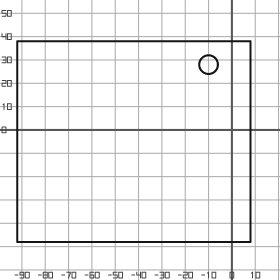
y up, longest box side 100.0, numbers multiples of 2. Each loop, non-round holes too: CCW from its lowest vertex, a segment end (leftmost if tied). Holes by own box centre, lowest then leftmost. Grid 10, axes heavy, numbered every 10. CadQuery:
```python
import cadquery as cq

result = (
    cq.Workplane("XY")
    .moveTo(-92.0, -48.0)
    .lineTo(8.0, -48.0)
    .lineTo(8.0, 38.0)
    .lineTo(-92.0, 38.0)
    .close()
    .moveTo(-10.0, 28.0)
    .circle(4.0)
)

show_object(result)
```